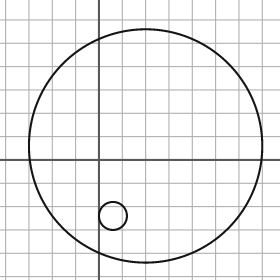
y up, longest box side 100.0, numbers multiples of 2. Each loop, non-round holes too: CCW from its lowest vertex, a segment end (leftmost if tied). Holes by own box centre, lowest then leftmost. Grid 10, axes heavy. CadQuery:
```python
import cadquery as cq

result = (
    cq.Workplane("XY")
    .moveTo(20.0, 6.0)
    .circle(50.0)
    .moveTo(6.0, -24.0)
    .circle(6.0)
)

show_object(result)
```